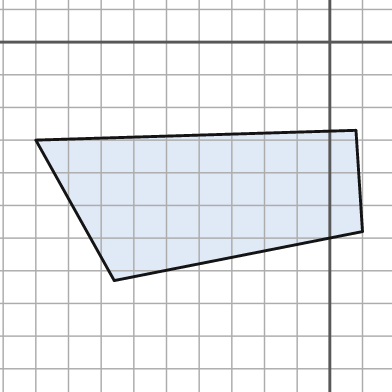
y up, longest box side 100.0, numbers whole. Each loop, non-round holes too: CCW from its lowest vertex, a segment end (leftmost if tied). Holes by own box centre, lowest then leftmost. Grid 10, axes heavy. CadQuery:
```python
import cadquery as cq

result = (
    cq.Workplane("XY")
    .moveTo(-66.0, -73.0)
    .lineTo(10.0, -58.0)
    .lineTo(8.0, -27.0)
    .lineTo(-90.0, -30.0)
    .close()
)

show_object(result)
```